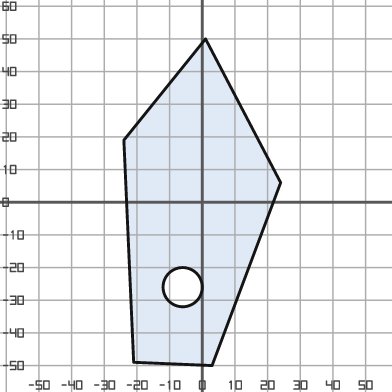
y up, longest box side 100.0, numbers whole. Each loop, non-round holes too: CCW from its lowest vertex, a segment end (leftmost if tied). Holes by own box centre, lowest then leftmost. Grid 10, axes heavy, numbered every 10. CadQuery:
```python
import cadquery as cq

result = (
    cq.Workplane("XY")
    .moveTo(3.0, -50.0)
    .lineTo(24.0, 6.0)
    .lineTo(1.0, 50.0)
    .lineTo(-24.0, 19.0)
    .lineTo(-21.0, -49.0)
    .close()
    .moveTo(-6.0, -26.0)
    .circle(6.0)
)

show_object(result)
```